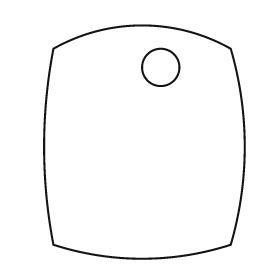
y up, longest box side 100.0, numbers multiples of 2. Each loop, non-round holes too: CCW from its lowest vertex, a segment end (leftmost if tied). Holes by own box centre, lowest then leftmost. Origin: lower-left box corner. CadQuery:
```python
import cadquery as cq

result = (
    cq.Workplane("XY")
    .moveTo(4.0, 6.0)
    .threePointArc((42.0, 0.0), (80.0, 6.0))
    .threePointArc((86.0, 48.0), (80.0, 90.0))
    .threePointArc((42.0, 100.0), (4.0, 90.0))
    .threePointArc((0.0, 48.0), (4.0, 6.0))
    .close()
    .moveTo(50.0, 82.0)
    .circle(8.0)
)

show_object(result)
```